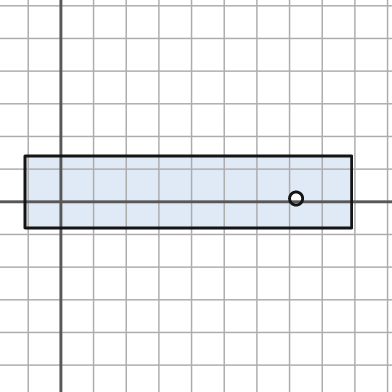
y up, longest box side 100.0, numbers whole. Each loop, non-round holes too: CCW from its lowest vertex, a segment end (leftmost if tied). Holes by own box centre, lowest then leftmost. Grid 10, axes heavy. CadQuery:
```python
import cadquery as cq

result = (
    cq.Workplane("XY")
    .moveTo(-11.0, -8.0)
    .lineTo(89.0, -8.0)
    .lineTo(89.0, 14.0)
    .lineTo(-11.0, 14.0)
    .close()
    .moveTo(72.0, 1.0)
    .circle(2.0)
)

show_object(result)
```